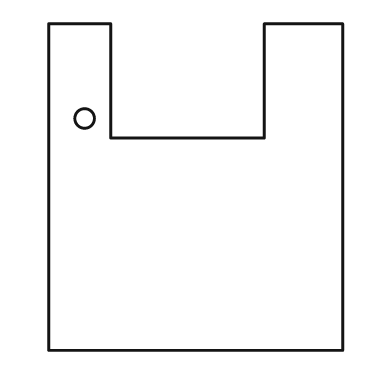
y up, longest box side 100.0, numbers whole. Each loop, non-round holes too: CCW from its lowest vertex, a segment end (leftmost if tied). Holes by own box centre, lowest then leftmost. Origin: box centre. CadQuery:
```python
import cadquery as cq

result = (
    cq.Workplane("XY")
    .moveTo(-45.0, -50.0)
    .lineTo(45.0, -50.0)
    .lineTo(45.0, 50.0)
    .lineTo(21.0, 50.0)
    .lineTo(21.0, 15.0)
    .lineTo(-26.0, 15.0)
    .lineTo(-26.0, 50.0)
    .lineTo(-45.0, 50.0)
    .close()
    .moveTo(-34.0, 21.0)
    .circle(3.0)
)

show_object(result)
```